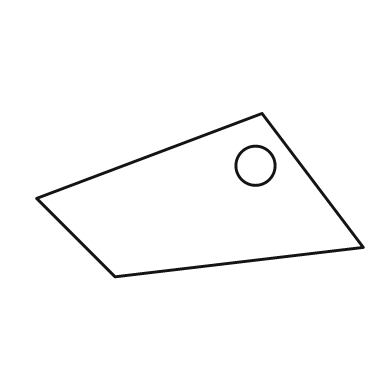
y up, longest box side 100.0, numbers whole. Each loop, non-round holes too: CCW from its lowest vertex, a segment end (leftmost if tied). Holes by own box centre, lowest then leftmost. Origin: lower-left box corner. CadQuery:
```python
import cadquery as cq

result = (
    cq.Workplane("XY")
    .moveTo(24.0, 0.0)
    .lineTo(100.0, 9.0)
    .lineTo(69.0, 50.0)
    .lineTo(0.0, 24.0)
    .close()
    .moveTo(67.0, 34.0)
    .circle(6.0)
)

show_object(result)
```